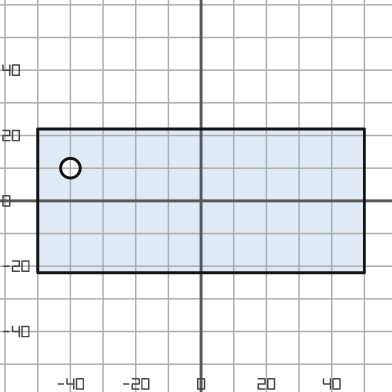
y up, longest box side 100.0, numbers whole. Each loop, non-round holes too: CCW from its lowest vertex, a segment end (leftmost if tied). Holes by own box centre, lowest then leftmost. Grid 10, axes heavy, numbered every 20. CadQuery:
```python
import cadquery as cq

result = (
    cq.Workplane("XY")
    .moveTo(-50.0, -22.0)
    .lineTo(50.0, -22.0)
    .lineTo(50.0, 22.0)
    .lineTo(-50.0, 22.0)
    .close()
    .moveTo(-40.0, 10.0)
    .circle(3.0)
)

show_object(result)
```